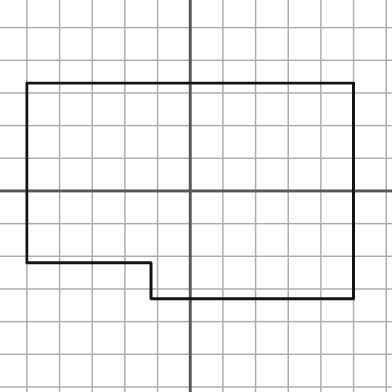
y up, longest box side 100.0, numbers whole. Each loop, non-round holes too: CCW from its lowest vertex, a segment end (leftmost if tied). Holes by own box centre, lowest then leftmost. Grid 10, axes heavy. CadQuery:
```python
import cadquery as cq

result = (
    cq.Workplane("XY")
    .moveTo(-12.0, -33.0)
    .lineTo(50.0, -33.0)
    .lineTo(50.0, 33.0)
    .lineTo(-50.0, 33.0)
    .lineTo(-50.0, -22.0)
    .lineTo(-12.0, -22.0)
    .close()
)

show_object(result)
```